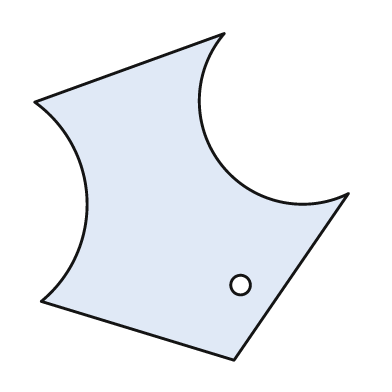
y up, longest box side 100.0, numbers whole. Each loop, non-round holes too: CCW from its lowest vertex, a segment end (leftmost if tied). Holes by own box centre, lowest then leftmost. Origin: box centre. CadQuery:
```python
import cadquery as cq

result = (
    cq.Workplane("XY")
    .moveTo(13.0, -50.0)
    .lineTo(48.0, 1.0)
    .threePointArc((9.0, 10.0), (10.0, 50.0))
    .lineTo(-48.0, 29.0)
    .threePointArc((-32.0, -1.0), (-46.0, -32.0))
    .close()
    .moveTo(15.0, -27.0)
    .circle(3.0)
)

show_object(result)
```